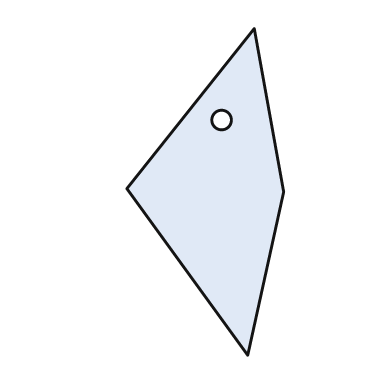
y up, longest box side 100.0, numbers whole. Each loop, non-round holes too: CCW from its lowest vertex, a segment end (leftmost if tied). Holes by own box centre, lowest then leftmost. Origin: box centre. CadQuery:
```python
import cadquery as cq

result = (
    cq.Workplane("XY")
    .moveTo(13.0, -50.0)
    .lineTo(24.0, 0.0)
    .lineTo(15.0, 50.0)
    .lineTo(-24.0, 1.0)
    .close()
    .moveTo(5.0, 22.0)
    .circle(3.0)
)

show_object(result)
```